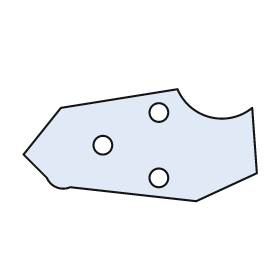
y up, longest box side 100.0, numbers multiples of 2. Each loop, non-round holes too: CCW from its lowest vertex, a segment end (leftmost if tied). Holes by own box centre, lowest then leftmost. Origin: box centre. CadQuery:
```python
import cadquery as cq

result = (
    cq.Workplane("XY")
    .moveTo(24.0, -24.0)
    .lineTo(50.0, -12.0)
    .lineTo(48.0, 16.0)
    .threePointArc((30.0, 12.0), (16.0, 24.0))
    .lineTo(-34.0, 16.0)
    .lineTo(-50.0, -4.0)
    .lineTo(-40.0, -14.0)
    .threePointArc((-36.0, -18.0), (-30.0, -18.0))
    .close()
    .moveTo(8.0, -14.0)
    .circle(4.0)
    .moveTo(-16.0, 0.0)
    .circle(4.0)
    .moveTo(8.0, 14.0)
    .circle(4.0)
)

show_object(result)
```